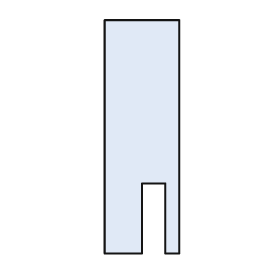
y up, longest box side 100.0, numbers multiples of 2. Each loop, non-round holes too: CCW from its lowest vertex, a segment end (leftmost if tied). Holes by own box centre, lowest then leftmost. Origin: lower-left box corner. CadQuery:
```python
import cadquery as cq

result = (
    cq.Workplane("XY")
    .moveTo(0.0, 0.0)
    .lineTo(16.0, 0.0)
    .lineTo(16.0, 30.0)
    .lineTo(26.0, 30.0)
    .lineTo(26.0, 0.0)
    .lineTo(32.0, 0.0)
    .lineTo(32.0, 100.0)
    .lineTo(0.0, 100.0)
    .close()
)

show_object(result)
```